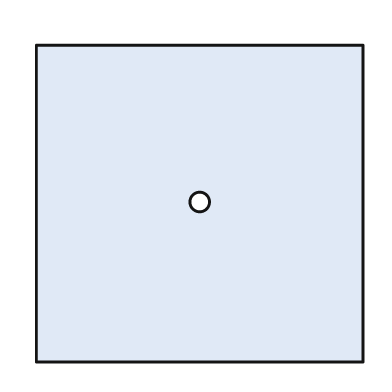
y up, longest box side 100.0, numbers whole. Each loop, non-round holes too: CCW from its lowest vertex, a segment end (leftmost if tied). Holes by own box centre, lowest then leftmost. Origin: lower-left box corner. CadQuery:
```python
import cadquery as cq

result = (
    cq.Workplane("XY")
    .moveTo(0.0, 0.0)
    .lineTo(100.0, 0.0)
    .lineTo(100.0, 97.0)
    .lineTo(0.0, 97.0)
    .close()
    .moveTo(50.0, 49.0)
    .circle(3.0)
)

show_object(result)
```